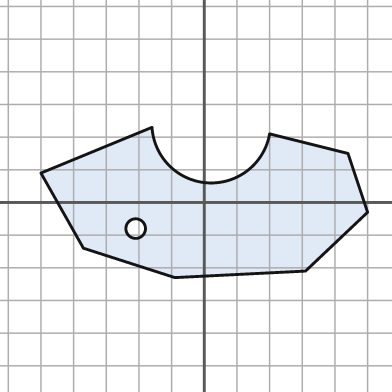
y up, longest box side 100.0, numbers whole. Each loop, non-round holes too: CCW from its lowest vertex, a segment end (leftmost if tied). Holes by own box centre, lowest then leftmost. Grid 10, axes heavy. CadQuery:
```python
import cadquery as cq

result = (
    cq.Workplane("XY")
    .moveTo(-9.0, -23.0)
    .lineTo(31.0, -21.0)
    .lineTo(50.0, -3.0)
    .lineTo(44.0, 15.0)
    .lineTo(20.0, 21.0)
    .threePointArc((1.0, 6.0), (-16.0, 23.0))
    .lineTo(-50.0, 9.0)
    .lineTo(-37.0, -14.0)
    .close()
    .moveTo(-21.0, -8.0)
    .circle(3.0)
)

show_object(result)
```